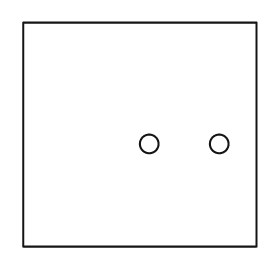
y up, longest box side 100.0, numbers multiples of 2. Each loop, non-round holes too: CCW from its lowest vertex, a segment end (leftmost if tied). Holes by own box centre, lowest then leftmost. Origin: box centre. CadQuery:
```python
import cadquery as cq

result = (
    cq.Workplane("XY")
    .moveTo(-50.0, -48.0)
    .lineTo(50.0, -48.0)
    .lineTo(50.0, 48.0)
    .lineTo(-50.0, 48.0)
    .close()
    .moveTo(4.0, -4.0)
    .circle(4.0)
    .moveTo(34.0, -4.0)
    .circle(4.0)
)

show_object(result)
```